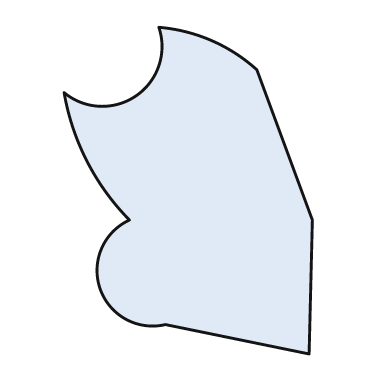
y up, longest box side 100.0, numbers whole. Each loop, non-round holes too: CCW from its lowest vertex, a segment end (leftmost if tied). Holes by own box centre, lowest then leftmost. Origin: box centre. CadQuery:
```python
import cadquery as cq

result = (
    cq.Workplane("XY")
    .moveTo(37.0, -50.0)
    .lineTo(38.0, -9.0)
    .lineTo(21.0, 37.0)
    .threePointArc((7.0, 46.0), (-9.0, 50.0))
    .threePointArc((-16.0, 29.0), (-38.0, 30.0))
    .threePointArc((-31.0, 9.0), (-18.0, -9.0))
    .threePointArc((-27.0, -30.0), (-7.0, -41.0))
    .close()
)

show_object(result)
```